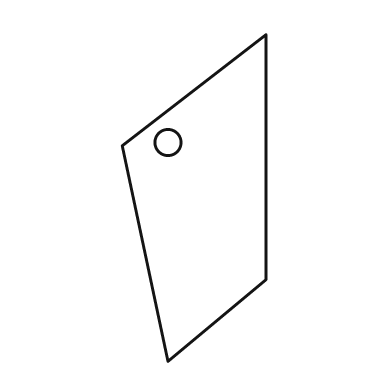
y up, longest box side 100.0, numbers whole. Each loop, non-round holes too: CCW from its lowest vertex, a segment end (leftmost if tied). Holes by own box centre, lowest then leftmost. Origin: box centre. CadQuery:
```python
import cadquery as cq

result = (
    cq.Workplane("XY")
    .moveTo(-8.0, -50.0)
    .lineTo(22.0, -25.0)
    .lineTo(22.0, 50.0)
    .lineTo(-22.0, 16.0)
    .close()
    .moveTo(-8.0, 17.0)
    .circle(4.0)
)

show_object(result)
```